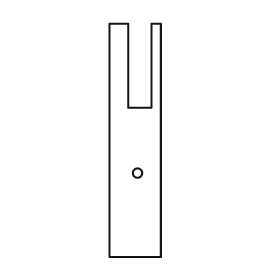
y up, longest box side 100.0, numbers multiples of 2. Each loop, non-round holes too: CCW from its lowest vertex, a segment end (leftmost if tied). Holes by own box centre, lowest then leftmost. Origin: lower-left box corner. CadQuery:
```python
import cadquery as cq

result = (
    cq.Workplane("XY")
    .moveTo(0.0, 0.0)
    .lineTo(22.0, 0.0)
    .lineTo(22.0, 100.0)
    .lineTo(18.0, 100.0)
    .lineTo(18.0, 64.0)
    .lineTo(8.0, 64.0)
    .lineTo(8.0, 100.0)
    .lineTo(0.0, 100.0)
    .close()
    .moveTo(12.0, 36.0)
    .circle(2.0)
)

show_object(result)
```